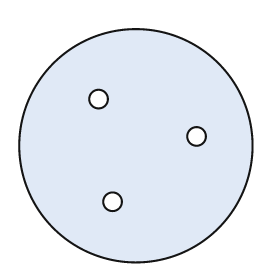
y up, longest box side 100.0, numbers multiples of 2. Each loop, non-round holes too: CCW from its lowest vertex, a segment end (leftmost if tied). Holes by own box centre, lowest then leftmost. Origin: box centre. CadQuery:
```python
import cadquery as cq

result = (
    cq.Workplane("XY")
    .moveTo(0.0, 0.0)
    .circle(50.0)
    .moveTo(-10.0, -24.0)
    .circle(4.0)
    .moveTo(26.0, 4.0)
    .circle(4.0)
    .moveTo(-16.0, 20.0)
    .circle(4.0)
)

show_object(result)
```